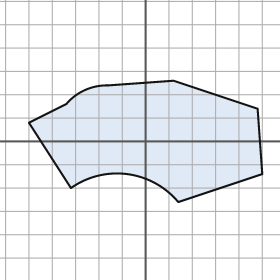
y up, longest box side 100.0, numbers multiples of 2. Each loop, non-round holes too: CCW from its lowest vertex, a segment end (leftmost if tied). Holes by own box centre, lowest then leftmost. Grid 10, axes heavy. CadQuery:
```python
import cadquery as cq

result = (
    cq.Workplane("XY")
    .moveTo(14.0, -26.0)
    .lineTo(50.0, -14.0)
    .lineTo(48.0, 14.0)
    .lineTo(12.0, 26.0)
    .lineTo(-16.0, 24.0)
    .threePointArc((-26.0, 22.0), (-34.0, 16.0))
    .lineTo(-50.0, 8.0)
    .lineTo(-32.0, -20.0)
    .threePointArc((-8.0, -14.0), (14.0, -26.0))
    .close()
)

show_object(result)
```